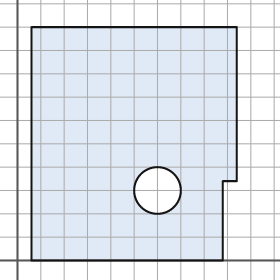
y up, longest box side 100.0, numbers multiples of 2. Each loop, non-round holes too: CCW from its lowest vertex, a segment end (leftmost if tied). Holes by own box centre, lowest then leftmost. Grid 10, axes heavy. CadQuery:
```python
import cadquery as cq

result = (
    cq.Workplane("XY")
    .moveTo(6.0, 0.0)
    .lineTo(88.0, 0.0)
    .lineTo(88.0, 34.0)
    .lineTo(94.0, 34.0)
    .lineTo(94.0, 100.0)
    .lineTo(6.0, 100.0)
    .close()
    .moveTo(60.0, 30.0)
    .circle(10.0)
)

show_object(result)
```